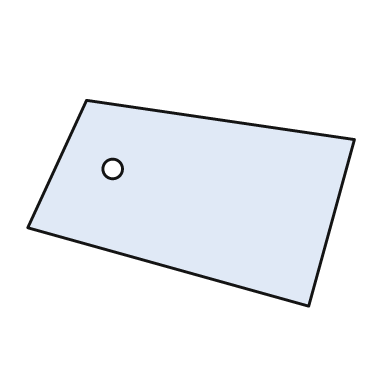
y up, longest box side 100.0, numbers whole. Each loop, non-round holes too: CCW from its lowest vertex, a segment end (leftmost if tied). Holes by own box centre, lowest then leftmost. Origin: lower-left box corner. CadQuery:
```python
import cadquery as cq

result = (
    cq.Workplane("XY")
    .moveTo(86.0, 0.0)
    .lineTo(100.0, 51.0)
    .lineTo(18.0, 63.0)
    .lineTo(0.0, 24.0)
    .close()
    .moveTo(26.0, 42.0)
    .circle(3.0)
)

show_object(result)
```